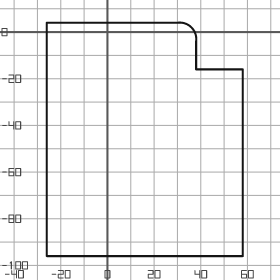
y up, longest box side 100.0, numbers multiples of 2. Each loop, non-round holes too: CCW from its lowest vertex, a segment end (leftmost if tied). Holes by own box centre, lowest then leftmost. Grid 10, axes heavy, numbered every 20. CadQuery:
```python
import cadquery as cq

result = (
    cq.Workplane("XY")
    .moveTo(-26.0, -96.0)
    .lineTo(58.0, -96.0)
    .lineTo(58.0, -16.0)
    .lineTo(38.0, -16.0)
    .lineTo(38.0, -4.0)
    .threePointArc((36.0, 2.0), (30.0, 4.0))
    .lineTo(-26.0, 4.0)
    .close()
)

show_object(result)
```